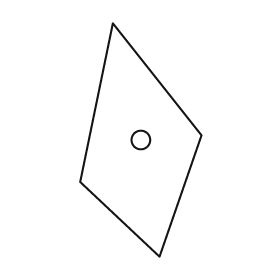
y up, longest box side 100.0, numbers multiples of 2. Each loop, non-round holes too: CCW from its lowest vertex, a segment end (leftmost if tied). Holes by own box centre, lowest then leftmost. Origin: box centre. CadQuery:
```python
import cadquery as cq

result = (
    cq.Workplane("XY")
    .moveTo(8.0, -50.0)
    .lineTo(26.0, 2.0)
    .lineTo(-12.0, 50.0)
    .lineTo(-26.0, -18.0)
    .close()
    .moveTo(0.0, 0.0)
    .circle(4.0)
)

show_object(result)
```